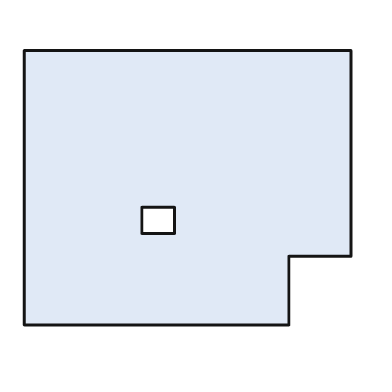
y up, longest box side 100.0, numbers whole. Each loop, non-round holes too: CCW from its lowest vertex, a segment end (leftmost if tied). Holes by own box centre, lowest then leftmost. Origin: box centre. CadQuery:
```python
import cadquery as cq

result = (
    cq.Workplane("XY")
    .moveTo(-50.0, -42.0)
    .lineTo(31.0, -42.0)
    .lineTo(31.0, -21.0)
    .lineTo(50.0, -21.0)
    .lineTo(50.0, 42.0)
    .lineTo(-50.0, 42.0)
    .close()
    .moveTo(-14.0, -14.0)
    .lineTo(-4.0, -14.0)
    .lineTo(-4.0, -6.0)
    .lineTo(-14.0, -6.0)
    .close()
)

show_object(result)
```